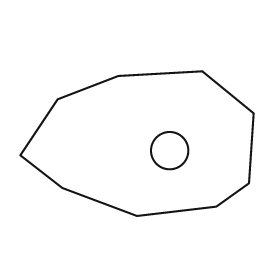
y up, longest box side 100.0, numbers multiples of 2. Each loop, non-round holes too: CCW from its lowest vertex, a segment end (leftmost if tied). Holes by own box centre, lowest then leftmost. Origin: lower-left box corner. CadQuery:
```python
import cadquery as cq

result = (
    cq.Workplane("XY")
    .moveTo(50.0, 0.0)
    .lineTo(84.0, 4.0)
    .lineTo(98.0, 14.0)
    .lineTo(100.0, 44.0)
    .lineTo(78.0, 62.0)
    .lineTo(42.0, 60.0)
    .lineTo(16.0, 50.0)
    .lineTo(0.0, 26.0)
    .lineTo(18.0, 12.0)
    .close()
    .moveTo(64.0, 28.0)
    .circle(8.0)
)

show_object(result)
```